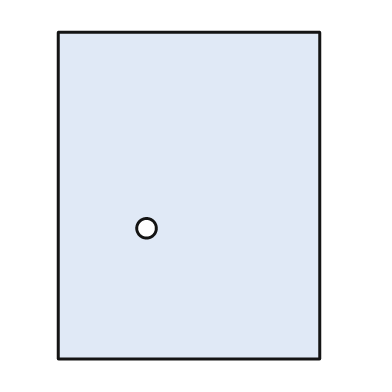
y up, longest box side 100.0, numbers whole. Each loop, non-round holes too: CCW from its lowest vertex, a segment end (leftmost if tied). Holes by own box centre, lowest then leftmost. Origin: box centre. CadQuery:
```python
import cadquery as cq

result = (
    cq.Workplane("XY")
    .moveTo(-40.0, -50.0)
    .lineTo(40.0, -50.0)
    .lineTo(40.0, 50.0)
    .lineTo(-40.0, 50.0)
    .close()
    .moveTo(-13.0, -10.0)
    .circle(3.0)
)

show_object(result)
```